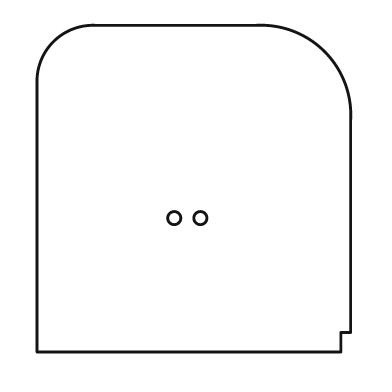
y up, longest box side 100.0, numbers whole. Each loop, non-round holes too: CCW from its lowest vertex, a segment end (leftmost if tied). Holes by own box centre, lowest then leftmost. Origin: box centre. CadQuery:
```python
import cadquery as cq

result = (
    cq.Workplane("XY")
    .moveTo(-48.0, -50.0)
    .lineTo(45.0, -50.0)
    .lineTo(45.0, -44.0)
    .lineTo(48.0, -44.0)
    .lineTo(48.0, 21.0)
    .threePointArc((40.0, 42.0), (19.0, 50.0))
    .lineTo(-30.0, 50.0)
    .threePointArc((-43.0, 45.0), (-48.0, 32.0))
    .close()
    .moveTo(-6.0, -9.0)
    .circle(2.0)
    .moveTo(2.0, -9.0)
    .circle(2.0)
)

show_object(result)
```